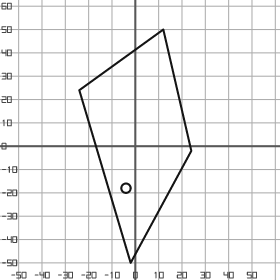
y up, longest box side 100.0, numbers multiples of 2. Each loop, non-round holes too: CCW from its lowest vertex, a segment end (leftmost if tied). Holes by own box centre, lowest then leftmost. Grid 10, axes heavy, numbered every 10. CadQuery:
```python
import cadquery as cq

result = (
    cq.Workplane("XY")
    .moveTo(-2.0, -50.0)
    .lineTo(24.0, -2.0)
    .lineTo(12.0, 50.0)
    .lineTo(-24.0, 24.0)
    .close()
    .moveTo(-4.0, -18.0)
    .circle(2.0)
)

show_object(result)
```